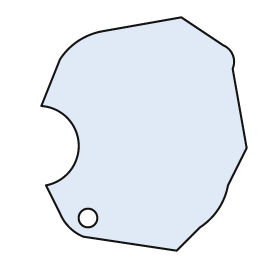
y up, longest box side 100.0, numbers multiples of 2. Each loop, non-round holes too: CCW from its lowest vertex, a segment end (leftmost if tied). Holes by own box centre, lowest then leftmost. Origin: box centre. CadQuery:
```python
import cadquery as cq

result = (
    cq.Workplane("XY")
    .moveTo(14.0, -50.0)
    .lineTo(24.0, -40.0)
    .threePointArc((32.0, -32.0), (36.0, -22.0))
    .lineTo(44.0, -6.0)
    .lineTo(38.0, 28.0)
    .threePointArc((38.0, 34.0), (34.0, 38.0))
    .lineTo(16.0, 50.0)
    .lineTo(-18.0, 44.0)
    .threePointArc((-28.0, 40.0), (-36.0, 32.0))
    .lineTo(-44.0, 12.0)
    .threePointArc((-28.0, -4.0), (-42.0, -22.0))
    .lineTo(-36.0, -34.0)
    .threePointArc((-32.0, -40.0), (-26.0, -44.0))
    .close()
    .moveTo(-24.0, -36.0)
    .circle(4.0)
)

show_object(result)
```